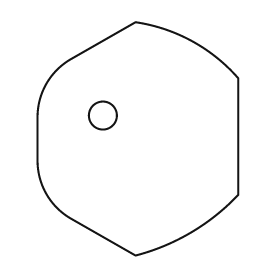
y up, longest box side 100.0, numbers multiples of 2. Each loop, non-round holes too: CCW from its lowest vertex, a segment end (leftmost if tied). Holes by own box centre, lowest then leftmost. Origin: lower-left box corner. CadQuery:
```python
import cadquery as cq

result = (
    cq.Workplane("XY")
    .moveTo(42.0, 0.0)
    .threePointArc((66.0, 10.0), (86.0, 26.0))
    .lineTo(86.0, 76.0)
    .threePointArc((66.0, 92.0), (42.0, 100.0))
    .lineTo(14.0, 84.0)
    .threePointArc((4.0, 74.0), (0.0, 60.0))
    .lineTo(0.0, 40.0)
    .threePointArc((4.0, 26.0), (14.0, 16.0))
    .close()
    .moveTo(28.0, 60.0)
    .circle(6.0)
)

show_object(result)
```